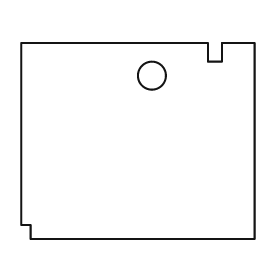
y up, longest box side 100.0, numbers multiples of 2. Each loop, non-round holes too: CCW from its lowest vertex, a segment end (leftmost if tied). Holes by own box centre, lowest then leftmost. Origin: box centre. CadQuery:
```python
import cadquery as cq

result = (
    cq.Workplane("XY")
    .moveTo(-46.0, -42.0)
    .lineTo(50.0, -42.0)
    .lineTo(50.0, 42.0)
    .lineTo(36.0, 42.0)
    .lineTo(36.0, 34.0)
    .lineTo(30.0, 34.0)
    .lineTo(30.0, 42.0)
    .lineTo(-50.0, 42.0)
    .lineTo(-50.0, -36.0)
    .lineTo(-46.0, -36.0)
    .close()
    .moveTo(6.0, 28.0)
    .circle(6.0)
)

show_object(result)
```